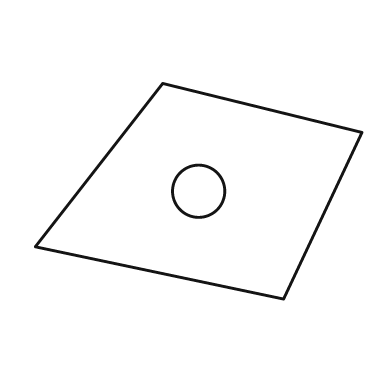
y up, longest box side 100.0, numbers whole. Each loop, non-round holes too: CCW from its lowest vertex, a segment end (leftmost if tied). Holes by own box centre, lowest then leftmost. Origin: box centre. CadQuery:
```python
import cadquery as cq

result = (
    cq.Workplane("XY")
    .moveTo(26.0, -33.0)
    .lineTo(50.0, 18.0)
    .lineTo(-11.0, 33.0)
    .lineTo(-50.0, -17.0)
    .close()
    .moveTo(0.0, 0.0)
    .circle(8.0)
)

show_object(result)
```